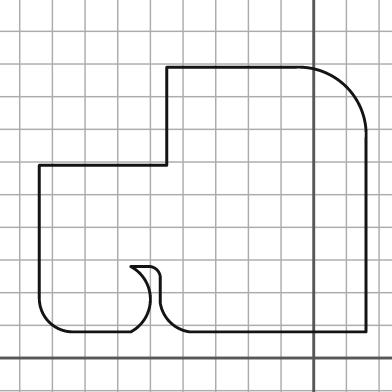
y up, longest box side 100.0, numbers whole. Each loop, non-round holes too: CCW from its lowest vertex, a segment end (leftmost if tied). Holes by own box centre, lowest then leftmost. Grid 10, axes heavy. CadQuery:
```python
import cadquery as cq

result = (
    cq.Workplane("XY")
    .moveTo(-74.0, 8.0)
    .lineTo(-56.0, 8.0)
    .threePointArc((-50.0, 18.0), (-56.0, 28.0))
    .lineTo(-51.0, 28.0)
    .threePointArc((-48.0, 27.0), (-47.0, 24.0))
    .lineTo(-47.0, 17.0)
    .threePointArc((-44.0, 11.0), (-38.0, 8.0))
    .lineTo(16.0, 8.0)
    .lineTo(16.0, 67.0)
    .threePointArc((10.0, 83.0), (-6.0, 89.0))
    .lineTo(-45.0, 89.0)
    .lineTo(-45.0, 59.0)
    .lineTo(-84.0, 59.0)
    .lineTo(-84.0, 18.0)
    .threePointArc((-81.0, 11.0), (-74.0, 8.0))
    .close()
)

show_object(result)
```